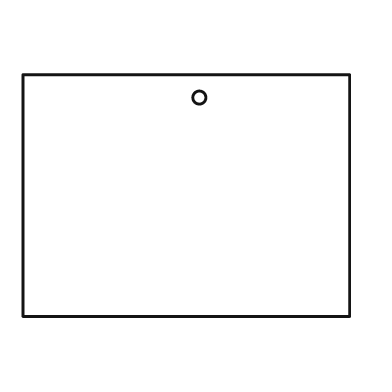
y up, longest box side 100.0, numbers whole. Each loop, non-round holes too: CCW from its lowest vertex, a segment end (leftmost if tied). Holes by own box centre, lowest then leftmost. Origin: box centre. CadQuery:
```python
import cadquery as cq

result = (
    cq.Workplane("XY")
    .moveTo(-50.0, -37.0)
    .lineTo(50.0, -37.0)
    .lineTo(50.0, 37.0)
    .lineTo(-50.0, 37.0)
    .close()
    .moveTo(4.0, 30.0)
    .circle(2.0)
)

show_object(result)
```